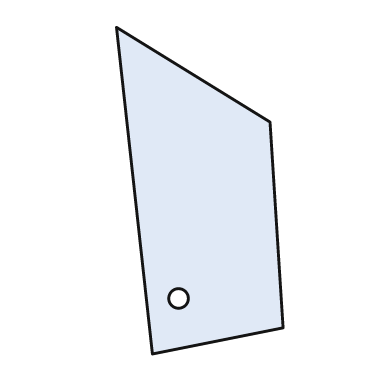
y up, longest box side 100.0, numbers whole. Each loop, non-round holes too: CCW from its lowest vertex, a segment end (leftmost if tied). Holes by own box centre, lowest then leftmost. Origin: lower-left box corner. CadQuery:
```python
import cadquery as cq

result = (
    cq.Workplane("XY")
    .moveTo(11.0, 0.0)
    .lineTo(51.0, 8.0)
    .lineTo(47.0, 71.0)
    .lineTo(0.0, 100.0)
    .close()
    .moveTo(19.0, 17.0)
    .circle(3.0)
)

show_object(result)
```